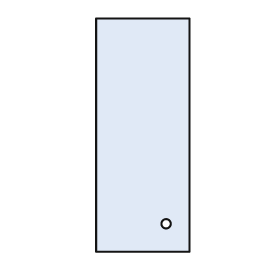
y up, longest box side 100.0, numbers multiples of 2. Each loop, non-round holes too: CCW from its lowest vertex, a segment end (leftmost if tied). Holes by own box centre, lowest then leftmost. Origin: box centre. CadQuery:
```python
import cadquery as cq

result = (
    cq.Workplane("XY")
    .moveTo(-20.0, -50.0)
    .lineTo(20.0, -50.0)
    .lineTo(20.0, 50.0)
    .lineTo(-20.0, 50.0)
    .close()
    .moveTo(10.0, -38.0)
    .circle(2.0)
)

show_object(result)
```